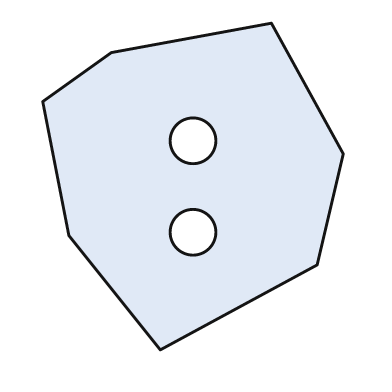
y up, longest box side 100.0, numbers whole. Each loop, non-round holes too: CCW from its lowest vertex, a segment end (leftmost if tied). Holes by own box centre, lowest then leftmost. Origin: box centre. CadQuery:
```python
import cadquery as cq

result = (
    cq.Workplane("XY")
    .moveTo(-10.0, -50.0)
    .lineTo(38.0, -24.0)
    .lineTo(46.0, 10.0)
    .lineTo(24.0, 50.0)
    .lineTo(-25.0, 41.0)
    .lineTo(-46.0, 26.0)
    .lineTo(-38.0, -15.0)
    .close()
    .moveTo(0.0, -14.0)
    .circle(7.0)
    .moveTo(0.0, 14.0)
    .circle(7.0)
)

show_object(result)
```